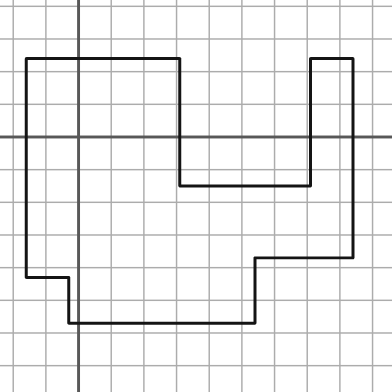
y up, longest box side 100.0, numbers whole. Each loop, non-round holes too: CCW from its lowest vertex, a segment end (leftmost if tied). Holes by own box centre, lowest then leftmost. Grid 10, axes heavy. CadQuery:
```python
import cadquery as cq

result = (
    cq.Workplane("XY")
    .moveTo(-3.0, -57.0)
    .lineTo(54.0, -57.0)
    .lineTo(54.0, -37.0)
    .lineTo(84.0, -37.0)
    .lineTo(84.0, 24.0)
    .lineTo(71.0, 24.0)
    .lineTo(71.0, -15.0)
    .lineTo(31.0, -15.0)
    .lineTo(31.0, 24.0)
    .lineTo(-16.0, 24.0)
    .lineTo(-16.0, -43.0)
    .lineTo(-3.0, -43.0)
    .close()
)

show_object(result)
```